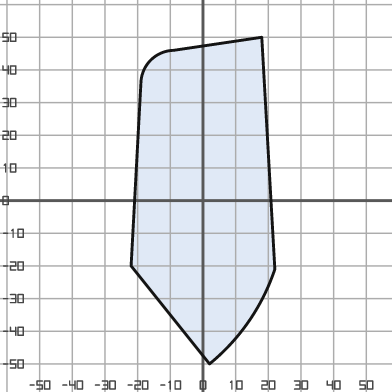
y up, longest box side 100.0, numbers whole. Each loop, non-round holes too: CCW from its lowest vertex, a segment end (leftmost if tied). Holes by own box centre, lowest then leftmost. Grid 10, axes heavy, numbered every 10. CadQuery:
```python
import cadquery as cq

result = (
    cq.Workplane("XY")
    .moveTo(2.0, -50.0)
    .threePointArc((14.0, -37.0), (22.0, -21.0))
    .lineTo(18.0, 50.0)
    .lineTo(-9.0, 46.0)
    .threePointArc((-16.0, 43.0), (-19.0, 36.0))
    .lineTo(-22.0, -20.0)
    .close()
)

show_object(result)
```